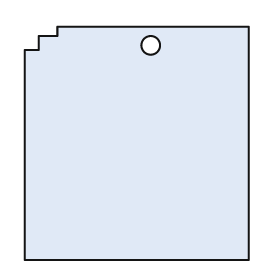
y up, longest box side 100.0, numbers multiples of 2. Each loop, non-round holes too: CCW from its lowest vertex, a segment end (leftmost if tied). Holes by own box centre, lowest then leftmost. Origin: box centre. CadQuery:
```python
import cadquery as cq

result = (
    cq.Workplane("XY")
    .moveTo(-48.0, -50.0)
    .lineTo(48.0, -50.0)
    .lineTo(48.0, 50.0)
    .lineTo(-34.0, 50.0)
    .lineTo(-34.0, 46.0)
    .lineTo(-42.0, 46.0)
    .lineTo(-42.0, 40.0)
    .lineTo(-48.0, 40.0)
    .close()
    .moveTo(6.0, 42.0)
    .circle(4.0)
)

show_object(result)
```